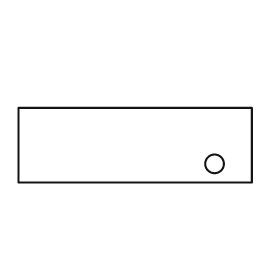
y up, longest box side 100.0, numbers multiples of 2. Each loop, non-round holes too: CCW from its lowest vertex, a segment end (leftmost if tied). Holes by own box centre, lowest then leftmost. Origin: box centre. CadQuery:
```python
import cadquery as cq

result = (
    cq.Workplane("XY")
    .moveTo(-50.0, -16.0)
    .lineTo(50.0, -16.0)
    .lineTo(50.0, 16.0)
    .lineTo(-50.0, 16.0)
    .close()
    .moveTo(34.0, -8.0)
    .circle(4.0)
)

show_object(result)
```